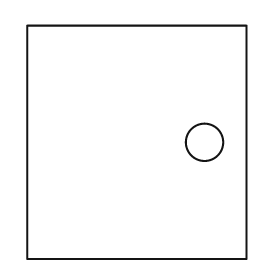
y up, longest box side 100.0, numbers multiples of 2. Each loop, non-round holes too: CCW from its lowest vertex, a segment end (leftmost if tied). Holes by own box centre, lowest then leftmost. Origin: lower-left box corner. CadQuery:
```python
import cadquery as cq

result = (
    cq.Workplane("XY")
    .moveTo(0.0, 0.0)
    .lineTo(94.0, 0.0)
    .lineTo(94.0, 100.0)
    .lineTo(0.0, 100.0)
    .close()
    .moveTo(76.0, 50.0)
    .circle(8.0)
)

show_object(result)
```